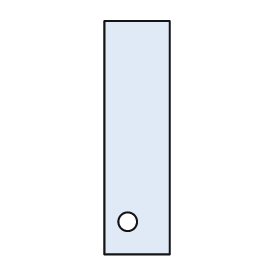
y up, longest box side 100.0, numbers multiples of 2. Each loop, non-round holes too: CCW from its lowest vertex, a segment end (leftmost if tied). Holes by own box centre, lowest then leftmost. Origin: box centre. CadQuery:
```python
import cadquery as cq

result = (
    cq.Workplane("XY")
    .moveTo(-14.0, -50.0)
    .lineTo(14.0, -50.0)
    .lineTo(14.0, 50.0)
    .lineTo(-14.0, 50.0)
    .close()
    .moveTo(-4.0, -36.0)
    .circle(4.0)
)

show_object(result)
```